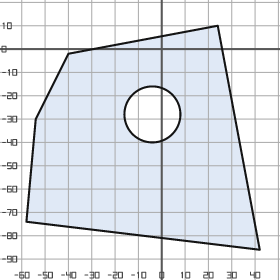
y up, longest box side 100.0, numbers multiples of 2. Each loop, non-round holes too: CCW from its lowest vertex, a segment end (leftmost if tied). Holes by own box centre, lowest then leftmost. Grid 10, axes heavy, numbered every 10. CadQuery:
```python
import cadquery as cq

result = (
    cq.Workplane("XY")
    .moveTo(42.0, -86.0)
    .lineTo(24.0, 10.0)
    .lineTo(-40.0, -2.0)
    .lineTo(-54.0, -30.0)
    .lineTo(-58.0, -74.0)
    .close()
    .moveTo(-4.0, -28.0)
    .circle(12.0)
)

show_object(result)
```